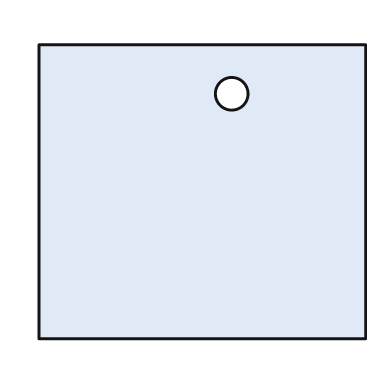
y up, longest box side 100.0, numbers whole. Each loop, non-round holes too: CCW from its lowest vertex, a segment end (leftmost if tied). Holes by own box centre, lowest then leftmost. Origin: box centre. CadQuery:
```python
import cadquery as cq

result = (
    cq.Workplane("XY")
    .moveTo(-50.0, -45.0)
    .lineTo(50.0, -45.0)
    .lineTo(50.0, 45.0)
    .lineTo(-50.0, 45.0)
    .close()
    .moveTo(9.0, 30.0)
    .circle(5.0)
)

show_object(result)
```